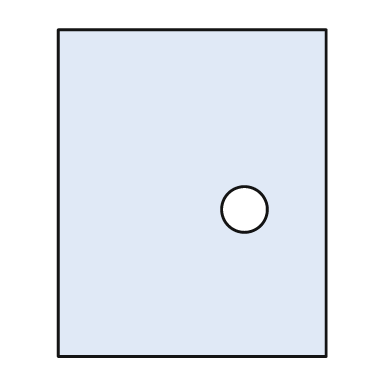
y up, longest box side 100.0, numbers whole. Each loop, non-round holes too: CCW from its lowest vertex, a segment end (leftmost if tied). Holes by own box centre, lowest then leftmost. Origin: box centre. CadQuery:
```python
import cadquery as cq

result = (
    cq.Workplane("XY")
    .moveTo(-41.0, -50.0)
    .lineTo(41.0, -50.0)
    .lineTo(41.0, 50.0)
    .lineTo(-41.0, 50.0)
    .close()
    .moveTo(16.0, -5.0)
    .circle(7.0)
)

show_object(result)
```